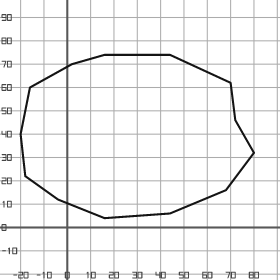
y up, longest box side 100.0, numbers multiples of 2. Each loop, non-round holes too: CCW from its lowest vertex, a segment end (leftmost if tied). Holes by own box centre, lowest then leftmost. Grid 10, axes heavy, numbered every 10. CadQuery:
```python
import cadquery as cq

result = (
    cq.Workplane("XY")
    .moveTo(16.0, 4.0)
    .lineTo(44.0, 6.0)
    .lineTo(68.0, 16.0)
    .lineTo(80.0, 32.0)
    .lineTo(72.0, 46.0)
    .lineTo(70.0, 62.0)
    .lineTo(44.0, 74.0)
    .lineTo(16.0, 74.0)
    .lineTo(2.0, 70.0)
    .lineTo(-16.0, 60.0)
    .lineTo(-20.0, 40.0)
    .lineTo(-18.0, 22.0)
    .lineTo(-4.0, 12.0)
    .close()
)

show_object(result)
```